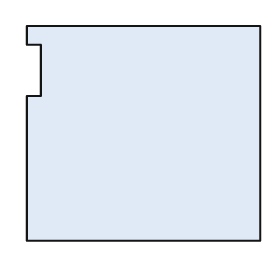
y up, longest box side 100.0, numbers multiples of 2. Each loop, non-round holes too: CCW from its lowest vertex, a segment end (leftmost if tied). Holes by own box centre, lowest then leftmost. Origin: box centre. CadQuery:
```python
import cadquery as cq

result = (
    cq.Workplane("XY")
    .moveTo(-50.0, -46.0)
    .lineTo(50.0, -46.0)
    .lineTo(50.0, 46.0)
    .lineTo(-50.0, 46.0)
    .lineTo(-50.0, 38.0)
    .lineTo(-44.0, 38.0)
    .lineTo(-44.0, 16.0)
    .lineTo(-50.0, 16.0)
    .close()
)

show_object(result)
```